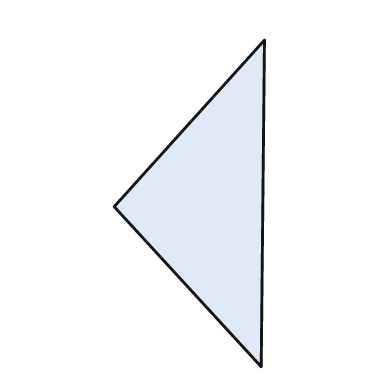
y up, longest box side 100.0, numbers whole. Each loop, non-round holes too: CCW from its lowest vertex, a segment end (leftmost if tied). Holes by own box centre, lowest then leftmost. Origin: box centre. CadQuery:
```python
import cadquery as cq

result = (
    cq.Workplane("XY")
    .moveTo(22.0, -50.0)
    .lineTo(23.0, 50.0)
    .lineTo(-23.0, -1.0)
    .close()
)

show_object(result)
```